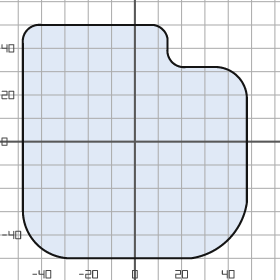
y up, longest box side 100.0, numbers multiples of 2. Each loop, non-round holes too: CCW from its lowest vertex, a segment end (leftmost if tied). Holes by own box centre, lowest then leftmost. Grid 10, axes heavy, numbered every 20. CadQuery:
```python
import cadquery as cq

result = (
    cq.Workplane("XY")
    .moveTo(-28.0, -50.0)
    .lineTo(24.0, -50.0)
    .threePointArc((40.0, -42.0), (48.0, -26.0))
    .lineTo(48.0, 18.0)
    .threePointArc((44.0, 28.0), (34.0, 32.0))
    .lineTo(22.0, 32.0)
    .threePointArc((16.0, 34.0), (14.0, 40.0))
    .lineTo(14.0, 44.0)
    .threePointArc((12.0, 48.0), (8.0, 50.0))
    .lineTo(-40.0, 50.0)
    .threePointArc((-46.0, 48.0), (-48.0, 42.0))
    .lineTo(-48.0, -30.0)
    .threePointArc((-42.0, -44.0), (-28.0, -50.0))
    .close()
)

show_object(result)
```